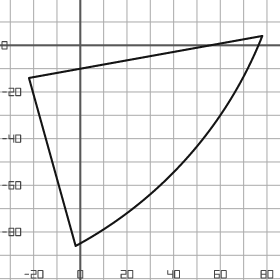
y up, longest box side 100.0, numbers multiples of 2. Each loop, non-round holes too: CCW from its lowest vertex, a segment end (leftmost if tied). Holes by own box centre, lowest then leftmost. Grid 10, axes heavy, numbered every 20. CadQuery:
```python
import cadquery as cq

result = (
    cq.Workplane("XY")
    .moveTo(-2.0, -86.0)
    .threePointArc((46.0, -48.0), (78.0, 4.0))
    .lineTo(-22.0, -14.0)
    .close()
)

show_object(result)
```